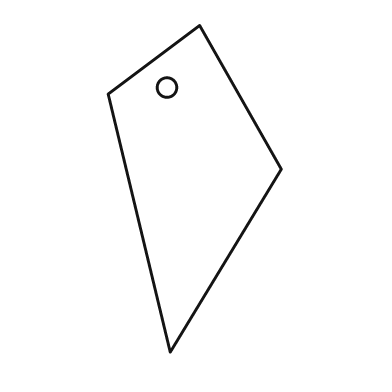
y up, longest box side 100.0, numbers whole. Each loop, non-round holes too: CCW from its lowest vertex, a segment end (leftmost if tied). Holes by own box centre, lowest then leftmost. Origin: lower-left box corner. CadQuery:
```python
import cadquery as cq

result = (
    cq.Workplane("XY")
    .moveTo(19.0, 0.0)
    .lineTo(53.0, 56.0)
    .lineTo(28.0, 100.0)
    .lineTo(0.0, 79.0)
    .close()
    .moveTo(18.0, 81.0)
    .circle(3.0)
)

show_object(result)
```